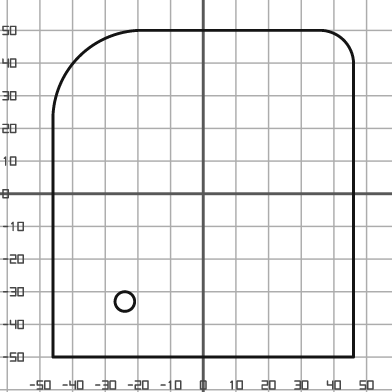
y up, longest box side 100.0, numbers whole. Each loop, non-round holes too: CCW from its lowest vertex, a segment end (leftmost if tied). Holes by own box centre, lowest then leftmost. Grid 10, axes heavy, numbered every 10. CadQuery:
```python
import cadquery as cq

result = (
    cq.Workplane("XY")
    .moveTo(-46.0, -50.0)
    .lineTo(46.0, -50.0)
    .lineTo(46.0, 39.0)
    .threePointArc((43.0, 47.0), (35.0, 50.0))
    .lineTo(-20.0, 50.0)
    .threePointArc((-38.0, 42.0), (-46.0, 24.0))
    .close()
    .moveTo(-24.0, -33.0)
    .circle(3.0)
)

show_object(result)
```